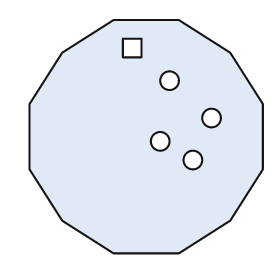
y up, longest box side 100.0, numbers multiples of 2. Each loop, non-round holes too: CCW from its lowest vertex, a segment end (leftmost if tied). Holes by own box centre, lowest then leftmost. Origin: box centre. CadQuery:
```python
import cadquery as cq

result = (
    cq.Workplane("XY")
    .moveTo(-14.0, -50.0)
    .lineTo(14.0, -50.0)
    .lineTo(36.0, -36.0)
    .lineTo(50.0, -14.0)
    .lineTo(50.0, 14.0)
    .lineTo(36.0, 36.0)
    .lineTo(14.0, 50.0)
    .lineTo(-14.0, 50.0)
    .lineTo(-36.0, 36.0)
    .lineTo(-50.0, 14.0)
    .lineTo(-50.0, -14.0)
    .lineTo(-36.0, -36.0)
    .close()
    .moveTo(20.0, -10.0)
    .circle(4.0)
    .moveTo(6.0, -2.0)
    .circle(4.0)
    .moveTo(28.0, 8.0)
    .circle(4.0)
    .moveTo(10.0, 24.0)
    .circle(4.0)
    .moveTo(-10.0, 34.0)
    .lineTo(-2.0, 34.0)
    .lineTo(-2.0, 42.0)
    .lineTo(-10.0, 42.0)
    .close()
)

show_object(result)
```